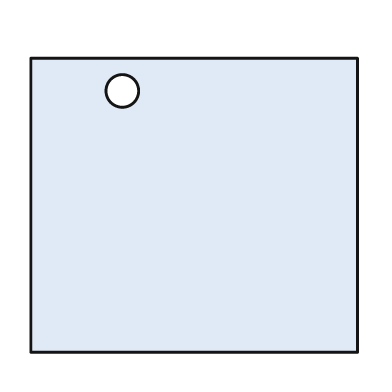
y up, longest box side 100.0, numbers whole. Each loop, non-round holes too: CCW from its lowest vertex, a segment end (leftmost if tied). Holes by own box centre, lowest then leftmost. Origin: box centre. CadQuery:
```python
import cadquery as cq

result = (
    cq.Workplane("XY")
    .moveTo(-50.0, -45.0)
    .lineTo(50.0, -45.0)
    .lineTo(50.0, 45.0)
    .lineTo(-50.0, 45.0)
    .close()
    .moveTo(-22.0, 35.0)
    .circle(5.0)
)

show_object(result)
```